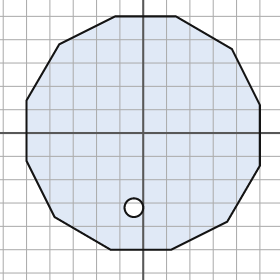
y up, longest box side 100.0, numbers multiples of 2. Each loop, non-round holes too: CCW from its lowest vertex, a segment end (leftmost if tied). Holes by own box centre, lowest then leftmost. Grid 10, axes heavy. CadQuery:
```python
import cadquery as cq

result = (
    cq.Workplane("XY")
    .moveTo(-14.0, -50.0)
    .lineTo(12.0, -50.0)
    .lineTo(36.0, -38.0)
    .lineTo(50.0, -14.0)
    .lineTo(50.0, 12.0)
    .lineTo(38.0, 36.0)
    .lineTo(14.0, 50.0)
    .lineTo(-12.0, 50.0)
    .lineTo(-36.0, 38.0)
    .lineTo(-50.0, 14.0)
    .lineTo(-50.0, -12.0)
    .lineTo(-38.0, -36.0)
    .close()
    .moveTo(-4.0, -32.0)
    .circle(4.0)
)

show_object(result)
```